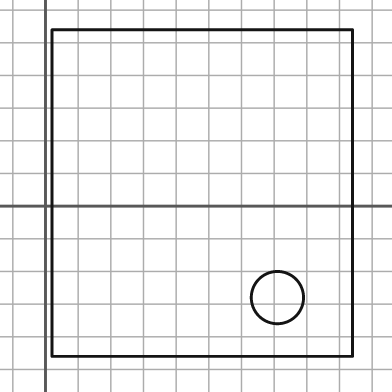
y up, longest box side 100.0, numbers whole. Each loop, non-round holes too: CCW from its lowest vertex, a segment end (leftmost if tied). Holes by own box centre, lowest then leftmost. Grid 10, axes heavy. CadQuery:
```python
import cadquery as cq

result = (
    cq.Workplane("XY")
    .moveTo(2.0, -46.0)
    .lineTo(94.0, -46.0)
    .lineTo(94.0, 54.0)
    .lineTo(2.0, 54.0)
    .close()
    .moveTo(71.0, -28.0)
    .circle(8.0)
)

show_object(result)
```